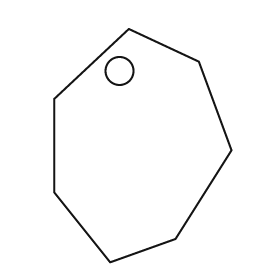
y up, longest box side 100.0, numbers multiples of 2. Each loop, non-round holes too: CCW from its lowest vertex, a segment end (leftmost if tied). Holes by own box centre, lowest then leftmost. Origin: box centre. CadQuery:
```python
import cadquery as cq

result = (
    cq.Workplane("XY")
    .moveTo(-14.0, -50.0)
    .lineTo(14.0, -40.0)
    .lineTo(38.0, -2.0)
    .lineTo(24.0, 36.0)
    .lineTo(-6.0, 50.0)
    .lineTo(-38.0, 20.0)
    .lineTo(-38.0, -20.0)
    .close()
    .moveTo(-10.0, 32.0)
    .circle(6.0)
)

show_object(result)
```